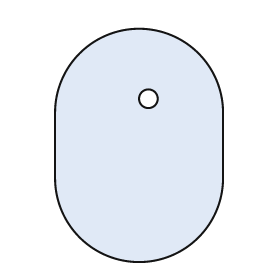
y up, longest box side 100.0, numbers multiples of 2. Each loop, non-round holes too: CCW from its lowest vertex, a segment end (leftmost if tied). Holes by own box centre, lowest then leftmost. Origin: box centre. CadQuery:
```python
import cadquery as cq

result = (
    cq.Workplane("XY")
    .moveTo(-36.0, -14.0)
    .threePointArc((0.0, -50.0), (36.0, -14.0))
    .lineTo(36.0, 14.0)
    .threePointArc((0.0, 50.0), (-36.0, 14.0))
    .close()
    .moveTo(4.0, 20.0)
    .circle(4.0)
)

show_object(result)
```